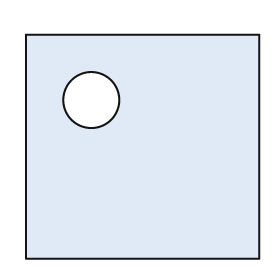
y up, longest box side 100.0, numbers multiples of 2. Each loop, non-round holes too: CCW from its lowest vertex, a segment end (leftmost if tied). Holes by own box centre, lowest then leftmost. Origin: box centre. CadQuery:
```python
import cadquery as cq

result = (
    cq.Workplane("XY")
    .moveTo(-50.0, -48.0)
    .lineTo(50.0, -48.0)
    .lineTo(50.0, 48.0)
    .lineTo(-50.0, 48.0)
    .close()
    .moveTo(-22.0, 20.0)
    .circle(12.0)
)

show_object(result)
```